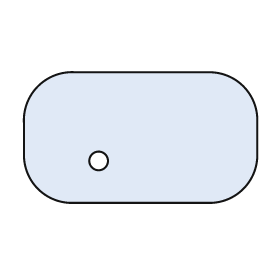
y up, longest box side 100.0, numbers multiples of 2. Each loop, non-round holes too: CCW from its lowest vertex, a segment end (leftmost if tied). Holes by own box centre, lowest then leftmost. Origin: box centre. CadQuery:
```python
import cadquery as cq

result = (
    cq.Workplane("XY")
    .moveTo(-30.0, -28.0)
    .lineTo(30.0, -28.0)
    .threePointArc((44.0, -22.0), (50.0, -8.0))
    .lineTo(50.0, 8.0)
    .threePointArc((44.0, 22.0), (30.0, 28.0))
    .lineTo(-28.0, 28.0)
    .threePointArc((-44.0, 22.0), (-50.0, 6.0))
    .lineTo(-50.0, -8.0)
    .threePointArc((-44.0, -22.0), (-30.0, -28.0))
    .close()
    .moveTo(-18.0, -10.0)
    .circle(4.0)
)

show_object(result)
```